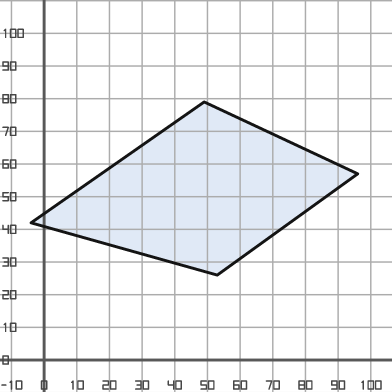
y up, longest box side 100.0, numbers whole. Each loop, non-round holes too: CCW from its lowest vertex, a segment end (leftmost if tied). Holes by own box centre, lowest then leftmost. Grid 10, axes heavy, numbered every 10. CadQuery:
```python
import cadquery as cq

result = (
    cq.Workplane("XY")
    .moveTo(53.0, 26.0)
    .lineTo(96.0, 57.0)
    .lineTo(49.0, 79.0)
    .lineTo(-4.0, 42.0)
    .close()
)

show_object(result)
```